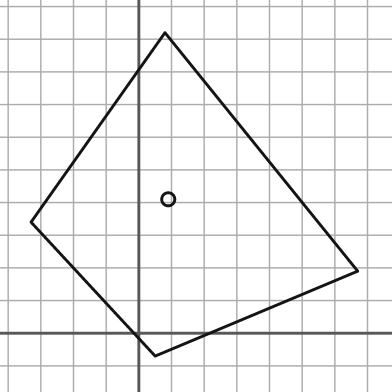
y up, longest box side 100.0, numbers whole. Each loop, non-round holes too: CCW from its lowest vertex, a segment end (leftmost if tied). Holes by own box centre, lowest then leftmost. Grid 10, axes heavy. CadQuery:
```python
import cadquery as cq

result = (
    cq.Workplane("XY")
    .moveTo(5.0, -7.0)
    .lineTo(67.0, 19.0)
    .lineTo(8.0, 92.0)
    .lineTo(-33.0, 34.0)
    .close()
    .moveTo(9.0, 41.0)
    .circle(2.0)
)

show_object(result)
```